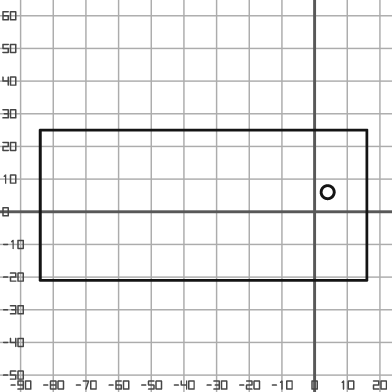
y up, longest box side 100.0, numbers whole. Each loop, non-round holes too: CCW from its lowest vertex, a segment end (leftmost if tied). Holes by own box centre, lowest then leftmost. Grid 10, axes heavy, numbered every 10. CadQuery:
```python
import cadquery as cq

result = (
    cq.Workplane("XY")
    .moveTo(-84.0, -21.0)
    .lineTo(16.0, -21.0)
    .lineTo(16.0, 25.0)
    .lineTo(-84.0, 25.0)
    .close()
    .moveTo(4.0, 6.0)
    .circle(2.0)
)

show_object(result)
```